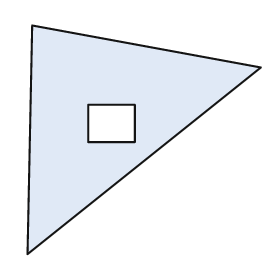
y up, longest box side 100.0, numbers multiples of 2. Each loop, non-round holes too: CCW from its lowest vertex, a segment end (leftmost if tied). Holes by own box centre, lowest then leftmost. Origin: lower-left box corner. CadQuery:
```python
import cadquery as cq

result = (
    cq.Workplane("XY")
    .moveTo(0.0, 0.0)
    .lineTo(100.0, 80.0)
    .lineTo(2.0, 98.0)
    .close()
    .moveTo(26.0, 48.0)
    .lineTo(46.0, 48.0)
    .lineTo(46.0, 64.0)
    .lineTo(26.0, 64.0)
    .close()
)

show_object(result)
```